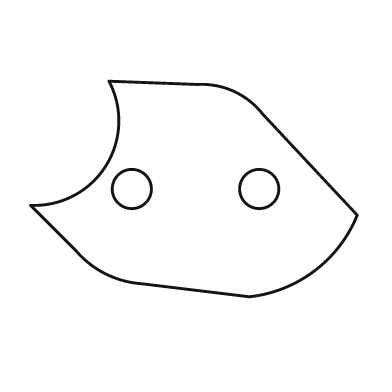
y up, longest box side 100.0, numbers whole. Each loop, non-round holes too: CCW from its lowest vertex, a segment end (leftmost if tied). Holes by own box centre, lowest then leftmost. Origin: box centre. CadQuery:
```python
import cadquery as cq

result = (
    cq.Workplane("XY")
    .moveTo(17.0, -33.0)
    .threePointArc((37.0, -25.0), (50.0, -8.0))
    .lineTo(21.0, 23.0)
    .threePointArc((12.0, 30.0), (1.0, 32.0))
    .lineTo(-26.0, 33.0)
    .threePointArc((-27.0, 7.0), (-50.0, -5.0))
    .lineTo(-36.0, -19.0)
    .threePointArc((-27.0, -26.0), (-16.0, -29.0))
    .close()
    .moveTo(-19.0, 0.0)
    .circle(6.0)
    .moveTo(20.0, 0.0)
    .circle(6.0)
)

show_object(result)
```